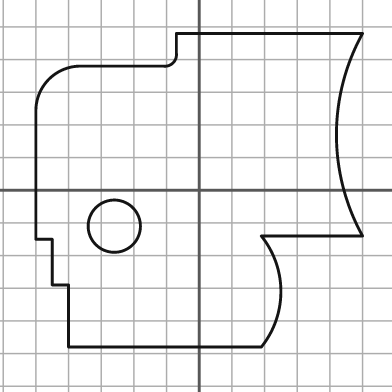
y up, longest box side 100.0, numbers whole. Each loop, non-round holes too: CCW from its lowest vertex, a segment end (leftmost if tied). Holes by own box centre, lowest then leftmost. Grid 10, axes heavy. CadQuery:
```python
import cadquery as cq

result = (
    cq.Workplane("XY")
    .moveTo(-40.0, -48.0)
    .lineTo(19.0, -48.0)
    .threePointArc((25.0, -31.0), (19.0, -14.0))
    .lineTo(50.0, -14.0)
    .threePointArc((42.0, 17.0), (50.0, 48.0))
    .lineTo(-7.0, 48.0)
    .lineTo(-7.0, 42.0)
    .threePointArc((-8.0, 39.0), (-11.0, 38.0))
    .lineTo(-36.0, 38.0)
    .threePointArc((-46.0, 34.0), (-50.0, 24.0))
    .lineTo(-50.0, -15.0)
    .lineTo(-45.0, -15.0)
    .lineTo(-45.0, -29.0)
    .lineTo(-40.0, -29.0)
    .close()
    .moveTo(-26.0, -11.0)
    .circle(8.0)
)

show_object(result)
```